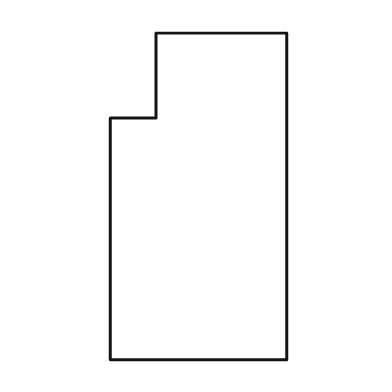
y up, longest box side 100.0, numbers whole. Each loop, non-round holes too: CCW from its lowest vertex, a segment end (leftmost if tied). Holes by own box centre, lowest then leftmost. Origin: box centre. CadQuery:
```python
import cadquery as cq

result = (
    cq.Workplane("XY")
    .moveTo(-27.0, -50.0)
    .lineTo(27.0, -50.0)
    .lineTo(27.0, 50.0)
    .lineTo(-13.0, 50.0)
    .lineTo(-13.0, 24.0)
    .lineTo(-27.0, 24.0)
    .close()
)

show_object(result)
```